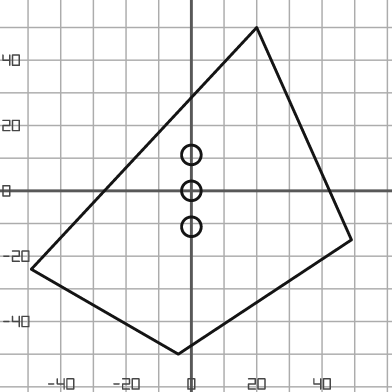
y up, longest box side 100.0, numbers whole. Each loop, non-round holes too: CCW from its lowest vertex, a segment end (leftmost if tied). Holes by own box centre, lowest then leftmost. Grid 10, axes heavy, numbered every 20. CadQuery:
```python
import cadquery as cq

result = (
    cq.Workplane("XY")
    .moveTo(-4.0, -50.0)
    .lineTo(49.0, -15.0)
    .lineTo(20.0, 50.0)
    .lineTo(-49.0, -24.0)
    .close()
    .moveTo(0.0, -11.0)
    .circle(3.0)
    .moveTo(0.0, 0.0)
    .circle(3.0)
    .moveTo(0.0, 11.0)
    .circle(3.0)
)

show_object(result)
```